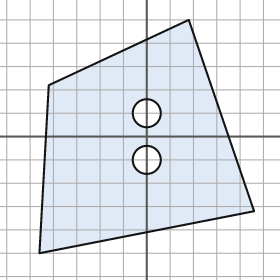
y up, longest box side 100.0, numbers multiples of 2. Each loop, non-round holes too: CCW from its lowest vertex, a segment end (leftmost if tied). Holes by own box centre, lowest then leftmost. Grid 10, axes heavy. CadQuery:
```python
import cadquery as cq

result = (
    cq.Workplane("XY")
    .moveTo(-46.0, -50.0)
    .lineTo(46.0, -32.0)
    .lineTo(18.0, 50.0)
    .lineTo(-42.0, 22.0)
    .close()
    .moveTo(0.0, -10.0)
    .circle(6.0)
    .moveTo(0.0, 10.0)
    .circle(6.0)
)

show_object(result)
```